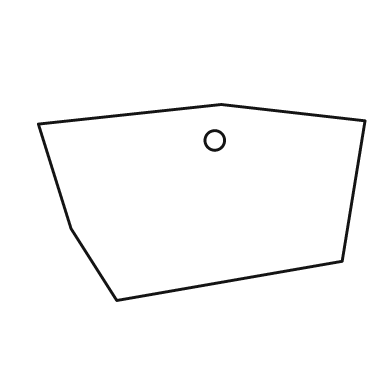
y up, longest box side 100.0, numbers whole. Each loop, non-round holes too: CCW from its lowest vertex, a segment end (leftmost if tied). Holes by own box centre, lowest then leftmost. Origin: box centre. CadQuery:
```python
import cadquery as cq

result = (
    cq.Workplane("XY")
    .moveTo(-26.0, -30.0)
    .lineTo(43.0, -18.0)
    .lineTo(50.0, 25.0)
    .lineTo(6.0, 30.0)
    .lineTo(-50.0, 24.0)
    .lineTo(-40.0, -8.0)
    .close()
    .moveTo(4.0, 19.0)
    .circle(3.0)
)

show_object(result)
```